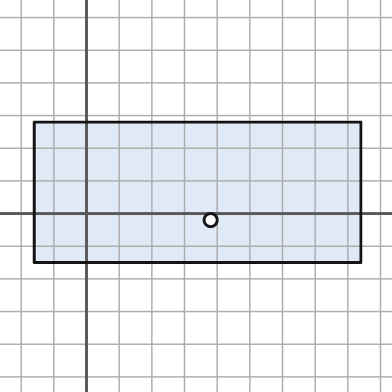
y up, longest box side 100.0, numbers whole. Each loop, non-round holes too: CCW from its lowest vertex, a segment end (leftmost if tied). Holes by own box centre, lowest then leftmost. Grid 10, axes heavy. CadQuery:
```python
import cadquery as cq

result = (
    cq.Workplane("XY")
    .moveTo(-16.0, -15.0)
    .lineTo(84.0, -15.0)
    .lineTo(84.0, 28.0)
    .lineTo(-16.0, 28.0)
    .close()
    .moveTo(38.0, -2.0)
    .circle(2.0)
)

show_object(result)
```